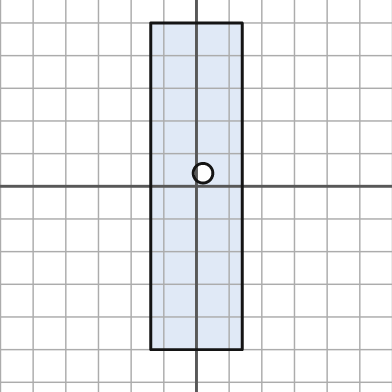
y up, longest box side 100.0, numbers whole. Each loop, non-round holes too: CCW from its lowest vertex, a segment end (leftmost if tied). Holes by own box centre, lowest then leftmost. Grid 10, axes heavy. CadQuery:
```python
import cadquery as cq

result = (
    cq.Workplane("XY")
    .moveTo(-14.0, -50.0)
    .lineTo(14.0, -50.0)
    .lineTo(14.0, 50.0)
    .lineTo(-14.0, 50.0)
    .close()
    .moveTo(2.0, 4.0)
    .circle(3.0)
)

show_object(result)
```